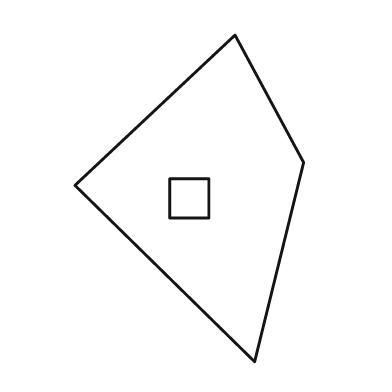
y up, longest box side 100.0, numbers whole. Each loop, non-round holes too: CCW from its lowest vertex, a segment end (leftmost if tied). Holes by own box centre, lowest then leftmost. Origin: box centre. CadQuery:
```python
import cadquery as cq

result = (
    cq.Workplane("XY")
    .moveTo(20.0, -50.0)
    .lineTo(35.0, 11.0)
    .lineTo(14.0, 50.0)
    .lineTo(-35.0, 4.0)
    .close()
    .moveTo(-6.0, -6.0)
    .lineTo(6.0, -6.0)
    .lineTo(6.0, 6.0)
    .lineTo(-6.0, 6.0)
    .close()
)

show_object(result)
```